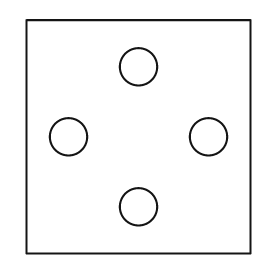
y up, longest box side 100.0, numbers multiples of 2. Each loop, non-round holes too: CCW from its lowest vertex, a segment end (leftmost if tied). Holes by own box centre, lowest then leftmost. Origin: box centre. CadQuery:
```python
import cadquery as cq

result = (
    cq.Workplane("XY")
    .moveTo(-48.0, -50.0)
    .lineTo(48.0, -50.0)
    .lineTo(48.0, 50.0)
    .lineTo(-48.0, 50.0)
    .close()
    .moveTo(0.0, -30.0)
    .circle(8.0)
    .moveTo(-30.0, 0.0)
    .circle(8.0)
    .moveTo(30.0, 0.0)
    .circle(8.0)
    .moveTo(0.0, 30.0)
    .circle(8.0)
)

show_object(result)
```